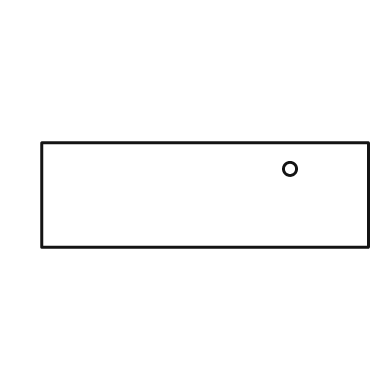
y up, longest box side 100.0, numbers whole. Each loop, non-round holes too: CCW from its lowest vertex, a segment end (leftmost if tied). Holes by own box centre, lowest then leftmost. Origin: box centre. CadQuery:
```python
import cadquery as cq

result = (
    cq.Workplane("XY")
    .moveTo(-50.0, -16.0)
    .lineTo(50.0, -16.0)
    .lineTo(50.0, 16.0)
    .lineTo(-50.0, 16.0)
    .close()
    .moveTo(26.0, 8.0)
    .circle(2.0)
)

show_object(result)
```